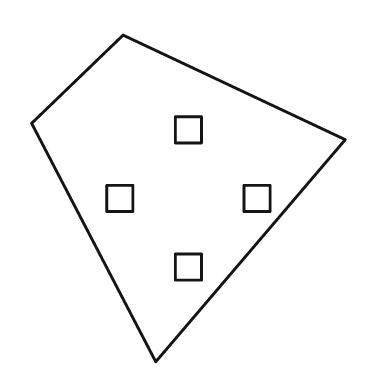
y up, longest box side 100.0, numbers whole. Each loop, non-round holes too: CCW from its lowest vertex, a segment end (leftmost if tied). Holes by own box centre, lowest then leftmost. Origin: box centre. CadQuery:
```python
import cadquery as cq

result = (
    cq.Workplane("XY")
    .moveTo(-10.0, -50.0)
    .lineTo(48.0, 18.0)
    .lineTo(-20.0, 50.0)
    .lineTo(-48.0, 23.0)
    .close()
    .moveTo(-4.0, -25.0)
    .lineTo(4.0, -25.0)
    .lineTo(4.0, -17.0)
    .lineTo(-4.0, -17.0)
    .close()
    .moveTo(-25.0, -4.0)
    .lineTo(-17.0, -4.0)
    .lineTo(-17.0, 4.0)
    .lineTo(-25.0, 4.0)
    .close()
    .moveTo(17.0, -4.0)
    .lineTo(25.0, -4.0)
    .lineTo(25.0, 4.0)
    .lineTo(17.0, 4.0)
    .close()
    .moveTo(-4.0, 17.0)
    .lineTo(4.0, 17.0)
    .lineTo(4.0, 25.0)
    .lineTo(-4.0, 25.0)
    .close()
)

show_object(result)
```